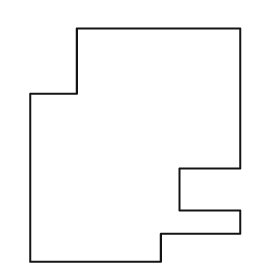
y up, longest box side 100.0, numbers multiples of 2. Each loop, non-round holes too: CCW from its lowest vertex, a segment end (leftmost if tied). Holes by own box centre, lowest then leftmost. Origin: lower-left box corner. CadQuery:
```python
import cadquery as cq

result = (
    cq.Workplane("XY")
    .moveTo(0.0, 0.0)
    .lineTo(56.0, 0.0)
    .lineTo(56.0, 12.0)
    .lineTo(90.0, 12.0)
    .lineTo(90.0, 22.0)
    .lineTo(64.0, 22.0)
    .lineTo(64.0, 40.0)
    .lineTo(90.0, 40.0)
    .lineTo(90.0, 100.0)
    .lineTo(20.0, 100.0)
    .lineTo(20.0, 72.0)
    .lineTo(0.0, 72.0)
    .close()
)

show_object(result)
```